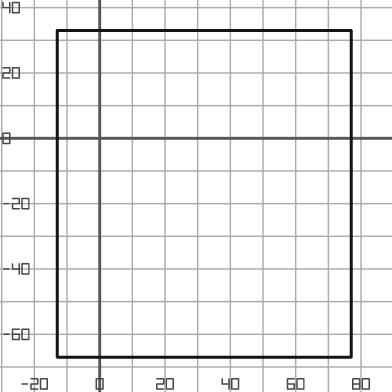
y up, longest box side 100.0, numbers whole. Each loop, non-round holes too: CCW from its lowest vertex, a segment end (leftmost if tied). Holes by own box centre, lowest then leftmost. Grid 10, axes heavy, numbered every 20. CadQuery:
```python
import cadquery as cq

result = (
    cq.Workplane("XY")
    .moveTo(-13.0, -67.0)
    .lineTo(77.0, -67.0)
    .lineTo(77.0, 33.0)
    .lineTo(-13.0, 33.0)
    .close()
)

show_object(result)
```